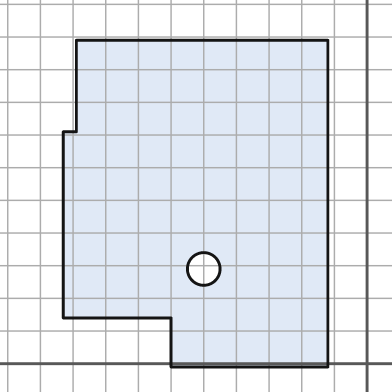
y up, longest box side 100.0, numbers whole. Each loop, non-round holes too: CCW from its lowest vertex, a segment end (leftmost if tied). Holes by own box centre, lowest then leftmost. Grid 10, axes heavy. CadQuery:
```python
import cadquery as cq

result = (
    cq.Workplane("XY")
    .moveTo(-60.0, -1.0)
    .lineTo(-12.0, -1.0)
    .lineTo(-12.0, 99.0)
    .lineTo(-89.0, 99.0)
    .lineTo(-89.0, 71.0)
    .lineTo(-93.0, 71.0)
    .lineTo(-93.0, 14.0)
    .lineTo(-60.0, 14.0)
    .close()
    .moveTo(-50.0, 29.0)
    .circle(5.0)
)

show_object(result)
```